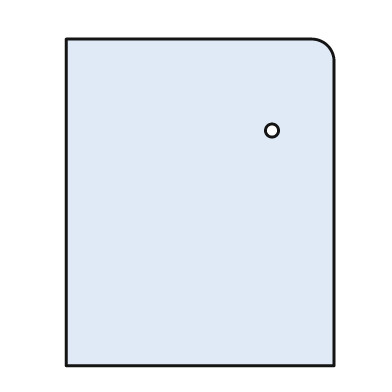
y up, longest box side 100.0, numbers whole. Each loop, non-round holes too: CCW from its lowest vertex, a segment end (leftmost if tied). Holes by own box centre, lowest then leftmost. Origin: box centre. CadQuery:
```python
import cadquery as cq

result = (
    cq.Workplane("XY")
    .moveTo(-41.0, -50.0)
    .lineTo(41.0, -50.0)
    .lineTo(41.0, 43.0)
    .threePointArc((39.0, 48.0), (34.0, 50.0))
    .lineTo(-41.0, 50.0)
    .close()
    .moveTo(22.0, 22.0)
    .circle(2.0)
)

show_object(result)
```